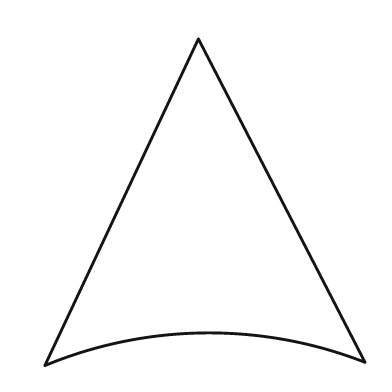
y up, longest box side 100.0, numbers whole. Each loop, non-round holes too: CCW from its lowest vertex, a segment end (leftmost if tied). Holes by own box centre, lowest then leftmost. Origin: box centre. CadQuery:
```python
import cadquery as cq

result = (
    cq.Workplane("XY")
    .moveTo(-49.0, -50.0)
    .threePointArc((0.0, -40.0), (49.0, -49.0))
    .lineTo(-2.0, 50.0)
    .close()
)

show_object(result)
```